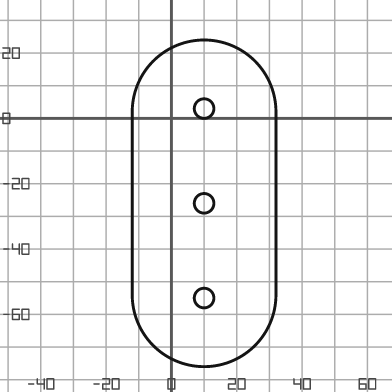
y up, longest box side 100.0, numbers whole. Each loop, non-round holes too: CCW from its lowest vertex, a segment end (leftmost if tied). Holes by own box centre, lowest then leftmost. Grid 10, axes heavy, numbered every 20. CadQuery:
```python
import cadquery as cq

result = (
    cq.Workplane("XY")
    .moveTo(-12.0, -54.0)
    .threePointArc((10.0, -76.0), (32.0, -54.0))
    .lineTo(32.0, 2.0)
    .threePointArc((10.0, 24.0), (-12.0, 2.0))
    .close()
    .moveTo(10.0, -55.0)
    .circle(3.0)
    .moveTo(10.0, -26.0)
    .circle(3.0)
    .moveTo(10.0, 3.0)
    .circle(3.0)
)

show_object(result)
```